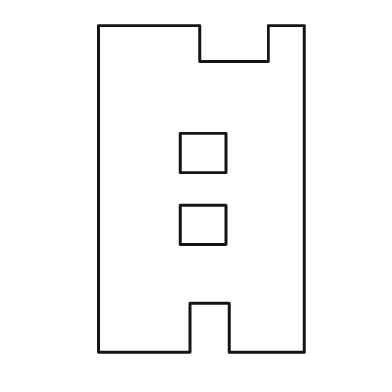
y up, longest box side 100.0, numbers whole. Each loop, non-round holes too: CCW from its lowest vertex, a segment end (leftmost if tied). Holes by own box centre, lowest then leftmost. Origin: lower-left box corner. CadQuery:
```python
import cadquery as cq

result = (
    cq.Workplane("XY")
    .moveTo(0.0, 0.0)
    .lineTo(28.0, 0.0)
    .lineTo(28.0, 15.0)
    .lineTo(40.0, 15.0)
    .lineTo(40.0, 0.0)
    .lineTo(63.0, 0.0)
    .lineTo(63.0, 100.0)
    .lineTo(52.0, 100.0)
    .lineTo(52.0, 89.0)
    .lineTo(31.0, 89.0)
    .lineTo(31.0, 100.0)
    .lineTo(0.0, 100.0)
    .close()
    .moveTo(25.0, 33.0)
    .lineTo(39.0, 33.0)
    .lineTo(39.0, 45.0)
    .lineTo(25.0, 45.0)
    .close()
    .moveTo(25.0, 55.0)
    .lineTo(39.0, 55.0)
    .lineTo(39.0, 67.0)
    .lineTo(25.0, 67.0)
    .close()
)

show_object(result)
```